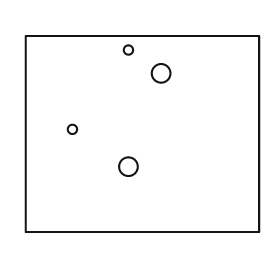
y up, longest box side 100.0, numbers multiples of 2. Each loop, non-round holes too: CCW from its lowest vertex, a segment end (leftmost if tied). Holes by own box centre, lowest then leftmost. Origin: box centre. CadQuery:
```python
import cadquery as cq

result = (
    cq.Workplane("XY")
    .moveTo(-50.0, -42.0)
    .lineTo(50.0, -42.0)
    .lineTo(50.0, 42.0)
    .lineTo(-50.0, 42.0)
    .close()
    .moveTo(-6.0, -14.0)
    .circle(4.0)
    .moveTo(-30.0, 2.0)
    .circle(2.0)
    .moveTo(8.0, 26.0)
    .circle(4.0)
    .moveTo(-6.0, 36.0)
    .circle(2.0)
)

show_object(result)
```